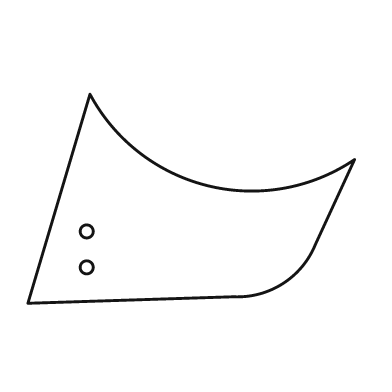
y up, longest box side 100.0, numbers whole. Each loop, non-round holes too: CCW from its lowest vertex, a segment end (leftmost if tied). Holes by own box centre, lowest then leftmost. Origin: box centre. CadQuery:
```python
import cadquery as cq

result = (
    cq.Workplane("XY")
    .moveTo(-50.0, -32.0)
    .lineTo(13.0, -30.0)
    .threePointArc((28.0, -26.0), (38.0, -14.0))
    .lineTo(50.0, 12.0)
    .threePointArc((5.0, 4.0), (-31.0, 32.0))
    .close()
    .moveTo(-32.0, -21.0)
    .circle(2.0)
    .moveTo(-32.0, -10.0)
    .circle(2.0)
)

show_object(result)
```